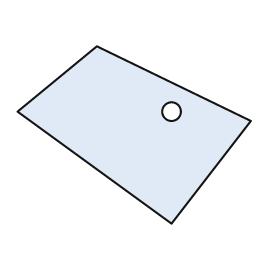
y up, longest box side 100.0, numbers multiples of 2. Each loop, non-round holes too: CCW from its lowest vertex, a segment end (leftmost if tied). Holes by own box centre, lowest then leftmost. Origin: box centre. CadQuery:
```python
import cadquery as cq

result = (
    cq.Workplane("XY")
    .moveTo(16.0, -38.0)
    .lineTo(50.0, 6.0)
    .lineTo(-16.0, 38.0)
    .lineTo(-50.0, 10.0)
    .close()
    .moveTo(16.0, 10.0)
    .circle(4.0)
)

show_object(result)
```